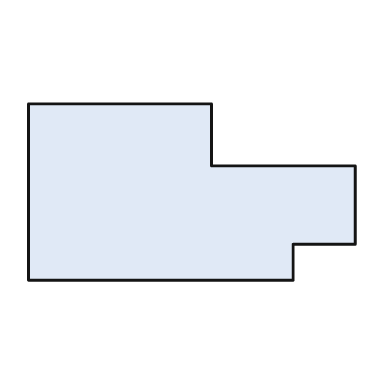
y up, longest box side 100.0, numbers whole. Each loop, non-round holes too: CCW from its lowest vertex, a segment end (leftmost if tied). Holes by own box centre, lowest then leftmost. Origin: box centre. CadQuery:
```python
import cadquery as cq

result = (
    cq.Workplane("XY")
    .moveTo(-50.0, -27.0)
    .lineTo(31.0, -27.0)
    .lineTo(31.0, -16.0)
    .lineTo(50.0, -16.0)
    .lineTo(50.0, 8.0)
    .lineTo(6.0, 8.0)
    .lineTo(6.0, 27.0)
    .lineTo(-50.0, 27.0)
    .close()
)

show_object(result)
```